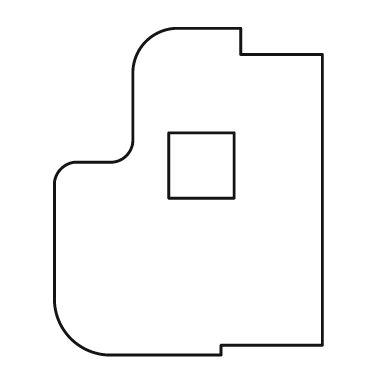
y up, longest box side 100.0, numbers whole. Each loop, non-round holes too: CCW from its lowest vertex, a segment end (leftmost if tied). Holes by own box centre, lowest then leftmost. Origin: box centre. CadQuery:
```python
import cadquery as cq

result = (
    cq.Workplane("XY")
    .moveTo(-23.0, -50.0)
    .lineTo(10.0, -50.0)
    .lineTo(10.0, -47.0)
    .lineTo(41.0, -47.0)
    .lineTo(41.0, 42.0)
    .lineTo(16.0, 42.0)
    .lineTo(16.0, 50.0)
    .lineTo(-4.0, 50.0)
    .threePointArc((-13.0, 46.0), (-17.0, 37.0))
    .lineTo(-17.0, 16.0)
    .threePointArc((-19.0, 11.0), (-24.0, 9.0))
    .lineTo(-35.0, 9.0)
    .threePointArc((-39.0, 7.0), (-41.0, 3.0))
    .lineTo(-41.0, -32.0)
    .threePointArc((-36.0, -45.0), (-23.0, -50.0))
    .close()
    .moveTo(-6.0, -2.0)
    .lineTo(14.0, -2.0)
    .lineTo(14.0, 18.0)
    .lineTo(-6.0, 18.0)
    .close()
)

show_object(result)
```